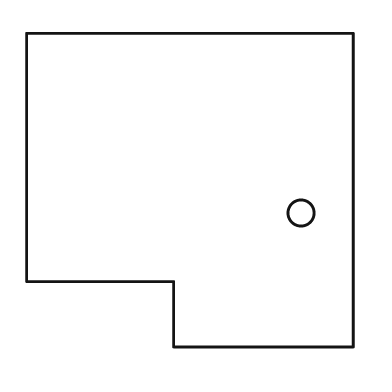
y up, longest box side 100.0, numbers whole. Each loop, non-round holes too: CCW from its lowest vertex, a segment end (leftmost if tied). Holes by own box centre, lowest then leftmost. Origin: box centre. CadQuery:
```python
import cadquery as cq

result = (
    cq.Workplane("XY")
    .moveTo(-5.0, -48.0)
    .lineTo(50.0, -48.0)
    .lineTo(50.0, 48.0)
    .lineTo(-50.0, 48.0)
    .lineTo(-50.0, -28.0)
    .lineTo(-5.0, -28.0)
    .close()
    .moveTo(34.0, -7.0)
    .circle(4.0)
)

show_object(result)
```